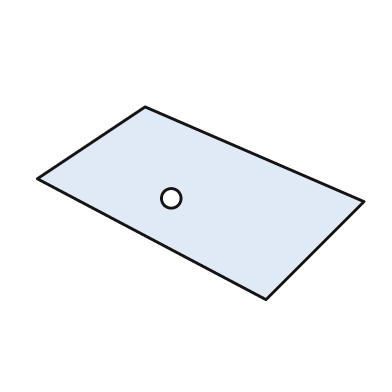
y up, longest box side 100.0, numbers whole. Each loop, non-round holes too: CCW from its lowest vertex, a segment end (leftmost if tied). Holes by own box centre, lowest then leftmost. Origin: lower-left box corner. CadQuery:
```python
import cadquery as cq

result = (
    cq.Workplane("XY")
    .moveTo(70.0, 0.0)
    .lineTo(100.0, 30.0)
    .lineTo(33.0, 59.0)
    .lineTo(0.0, 37.0)
    .close()
    .moveTo(41.0, 31.0)
    .circle(3.0)
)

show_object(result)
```